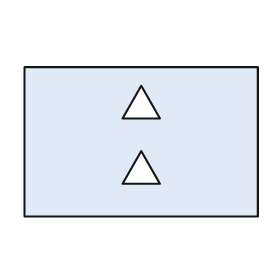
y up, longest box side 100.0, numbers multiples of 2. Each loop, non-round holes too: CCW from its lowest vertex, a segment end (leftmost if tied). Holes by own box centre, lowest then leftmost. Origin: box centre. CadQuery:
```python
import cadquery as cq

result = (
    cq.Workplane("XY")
    .moveTo(-50.0, -32.0)
    .lineTo(50.0, -32.0)
    .lineTo(50.0, 32.0)
    .lineTo(-50.0, 32.0)
    .close()
    .moveTo(-8.0, -18.0)
    .lineTo(8.0, -18.0)
    .lineTo(0.0, -4.0)
    .close()
    .moveTo(-8.0, 10.0)
    .lineTo(8.0, 10.0)
    .lineTo(0.0, 24.0)
    .close()
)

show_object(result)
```